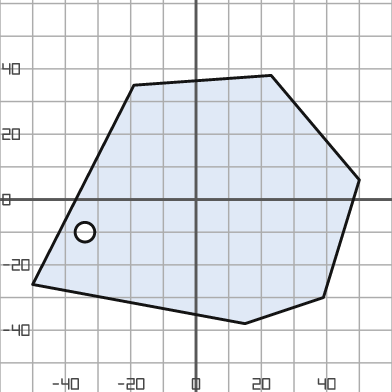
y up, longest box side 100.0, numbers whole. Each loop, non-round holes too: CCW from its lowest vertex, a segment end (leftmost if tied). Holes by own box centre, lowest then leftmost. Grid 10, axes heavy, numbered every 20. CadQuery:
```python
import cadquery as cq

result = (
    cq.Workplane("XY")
    .moveTo(15.0, -38.0)
    .lineTo(39.0, -30.0)
    .lineTo(50.0, 6.0)
    .lineTo(23.0, 38.0)
    .lineTo(-19.0, 35.0)
    .lineTo(-50.0, -26.0)
    .close()
    .moveTo(-34.0, -10.0)
    .circle(3.0)
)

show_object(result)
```